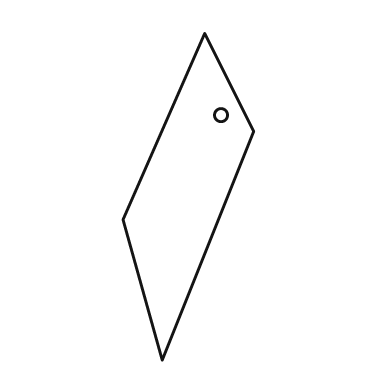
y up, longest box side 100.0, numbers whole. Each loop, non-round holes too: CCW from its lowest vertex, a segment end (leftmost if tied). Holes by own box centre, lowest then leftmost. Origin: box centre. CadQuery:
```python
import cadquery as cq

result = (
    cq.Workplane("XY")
    .moveTo(-8.0, -50.0)
    .lineTo(20.0, 20.0)
    .lineTo(5.0, 50.0)
    .lineTo(-20.0, -7.0)
    .close()
    .moveTo(10.0, 25.0)
    .circle(2.0)
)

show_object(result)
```